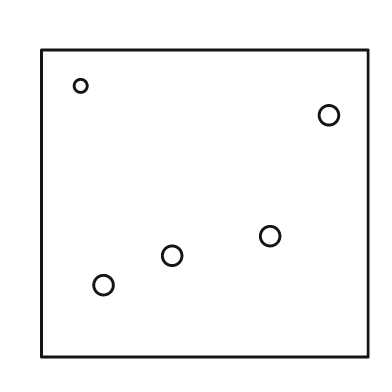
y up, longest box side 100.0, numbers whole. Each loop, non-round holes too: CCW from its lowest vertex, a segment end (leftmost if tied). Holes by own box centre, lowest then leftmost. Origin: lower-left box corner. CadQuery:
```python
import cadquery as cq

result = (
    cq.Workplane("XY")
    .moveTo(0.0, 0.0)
    .lineTo(100.0, 0.0)
    .lineTo(100.0, 94.0)
    .lineTo(0.0, 94.0)
    .close()
    .moveTo(19.0, 22.0)
    .circle(3.0)
    .moveTo(40.0, 31.0)
    .circle(3.0)
    .moveTo(70.0, 37.0)
    .circle(3.0)
    .moveTo(88.0, 74.0)
    .circle(3.0)
    .moveTo(12.0, 83.0)
    .circle(2.0)
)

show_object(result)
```